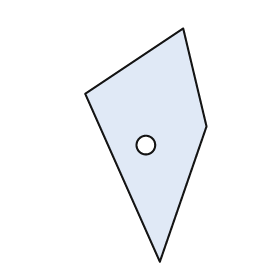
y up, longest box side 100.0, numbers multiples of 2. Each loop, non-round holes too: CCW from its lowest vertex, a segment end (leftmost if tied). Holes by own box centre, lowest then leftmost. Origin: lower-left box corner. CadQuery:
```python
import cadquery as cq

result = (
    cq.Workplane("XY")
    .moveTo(32.0, 0.0)
    .lineTo(52.0, 58.0)
    .lineTo(42.0, 100.0)
    .lineTo(0.0, 72.0)
    .close()
    .moveTo(26.0, 50.0)
    .circle(4.0)
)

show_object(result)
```